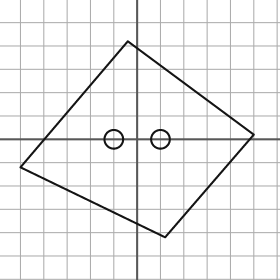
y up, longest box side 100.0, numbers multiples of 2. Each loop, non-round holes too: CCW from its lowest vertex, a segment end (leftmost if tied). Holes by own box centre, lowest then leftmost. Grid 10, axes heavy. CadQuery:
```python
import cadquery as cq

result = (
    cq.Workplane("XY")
    .moveTo(12.0, -42.0)
    .lineTo(50.0, 2.0)
    .lineTo(-4.0, 42.0)
    .lineTo(-50.0, -12.0)
    .close()
    .moveTo(-10.0, 0.0)
    .circle(4.0)
    .moveTo(10.0, 0.0)
    .circle(4.0)
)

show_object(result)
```